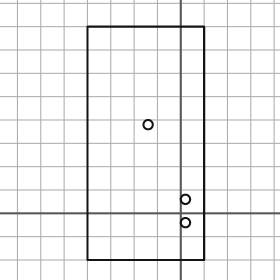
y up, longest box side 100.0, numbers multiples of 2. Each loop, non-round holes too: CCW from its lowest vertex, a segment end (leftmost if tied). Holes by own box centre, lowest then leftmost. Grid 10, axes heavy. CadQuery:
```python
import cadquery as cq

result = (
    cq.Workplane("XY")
    .moveTo(-40.0, -20.0)
    .lineTo(10.0, -20.0)
    .lineTo(10.0, 80.0)
    .lineTo(-40.0, 80.0)
    .close()
    .moveTo(2.0, -4.0)
    .circle(2.0)
    .moveTo(2.0, 6.0)
    .circle(2.0)
    .moveTo(-14.0, 38.0)
    .circle(2.0)
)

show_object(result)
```